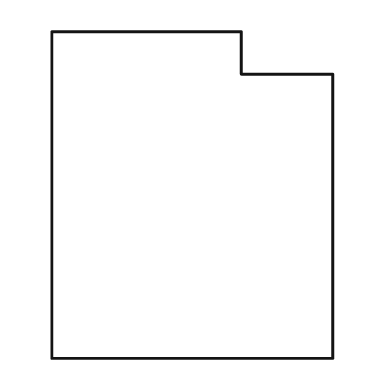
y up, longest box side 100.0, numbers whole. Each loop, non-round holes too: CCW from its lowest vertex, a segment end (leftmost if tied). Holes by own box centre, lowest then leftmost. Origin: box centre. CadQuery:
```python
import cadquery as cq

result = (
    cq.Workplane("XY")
    .moveTo(-43.0, -50.0)
    .lineTo(43.0, -50.0)
    .lineTo(43.0, 37.0)
    .lineTo(15.0, 37.0)
    .lineTo(15.0, 50.0)
    .lineTo(-43.0, 50.0)
    .close()
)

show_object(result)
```